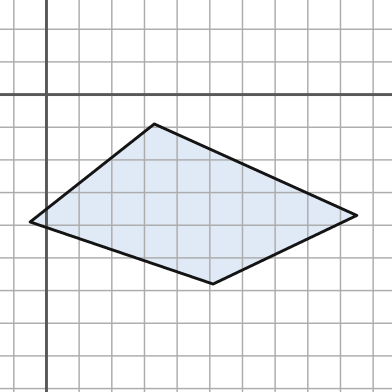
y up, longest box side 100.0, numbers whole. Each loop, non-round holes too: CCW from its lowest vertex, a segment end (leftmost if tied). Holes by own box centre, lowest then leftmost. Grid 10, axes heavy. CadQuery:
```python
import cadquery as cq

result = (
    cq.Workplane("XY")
    .moveTo(51.0, -58.0)
    .lineTo(95.0, -37.0)
    .lineTo(33.0, -9.0)
    .lineTo(-5.0, -39.0)
    .close()
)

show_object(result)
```